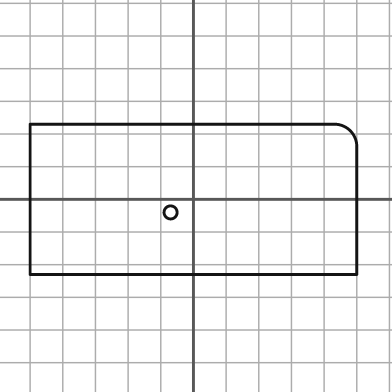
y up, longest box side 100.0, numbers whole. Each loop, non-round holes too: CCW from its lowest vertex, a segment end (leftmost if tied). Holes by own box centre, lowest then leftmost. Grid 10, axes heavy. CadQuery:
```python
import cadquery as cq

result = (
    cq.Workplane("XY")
    .moveTo(-50.0, -23.0)
    .lineTo(50.0, -23.0)
    .lineTo(50.0, 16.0)
    .threePointArc((48.0, 21.0), (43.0, 23.0))
    .lineTo(-50.0, 23.0)
    .close()
    .moveTo(-7.0, -4.0)
    .circle(2.0)
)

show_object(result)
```